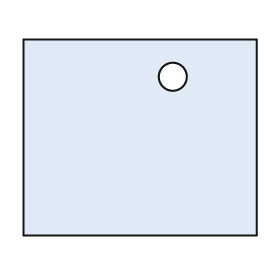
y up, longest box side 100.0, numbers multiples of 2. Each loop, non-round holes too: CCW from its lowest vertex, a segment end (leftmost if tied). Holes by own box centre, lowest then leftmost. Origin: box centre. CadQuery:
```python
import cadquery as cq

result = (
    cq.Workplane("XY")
    .moveTo(-50.0, -42.0)
    .lineTo(50.0, -42.0)
    .lineTo(50.0, 42.0)
    .lineTo(-50.0, 42.0)
    .close()
    .moveTo(14.0, 26.0)
    .circle(6.0)
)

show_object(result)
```